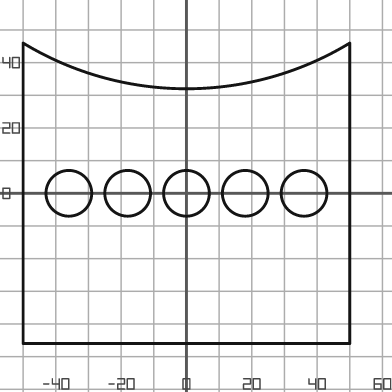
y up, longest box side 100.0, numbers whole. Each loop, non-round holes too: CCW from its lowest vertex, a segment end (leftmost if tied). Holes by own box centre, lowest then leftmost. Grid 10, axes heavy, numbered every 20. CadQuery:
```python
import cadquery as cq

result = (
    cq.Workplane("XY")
    .moveTo(-50.0, -46.0)
    .lineTo(50.0, -46.0)
    .lineTo(50.0, 46.0)
    .threePointArc((0.0, 32.0), (-50.0, 46.0))
    .close()
    .moveTo(-36.0, 0.0)
    .circle(7.0)
    .moveTo(-18.0, 0.0)
    .circle(7.0)
    .moveTo(0.0, 0.0)
    .circle(7.0)
    .moveTo(18.0, 0.0)
    .circle(7.0)
    .moveTo(36.0, 0.0)
    .circle(7.0)
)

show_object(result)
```